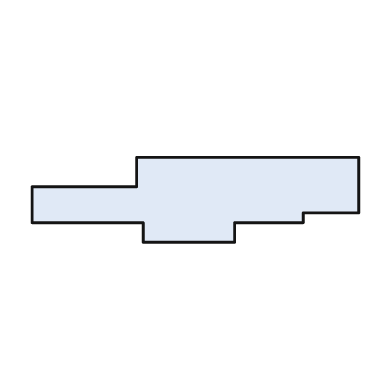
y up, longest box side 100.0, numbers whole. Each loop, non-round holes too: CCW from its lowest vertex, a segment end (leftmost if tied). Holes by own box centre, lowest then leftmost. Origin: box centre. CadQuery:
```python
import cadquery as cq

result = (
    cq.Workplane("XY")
    .moveTo(-16.0, -13.0)
    .lineTo(12.0, -13.0)
    .lineTo(12.0, -7.0)
    .lineTo(33.0, -7.0)
    .lineTo(33.0, -4.0)
    .lineTo(50.0, -4.0)
    .lineTo(50.0, 13.0)
    .lineTo(-18.0, 13.0)
    .lineTo(-18.0, 4.0)
    .lineTo(-50.0, 4.0)
    .lineTo(-50.0, -7.0)
    .lineTo(-16.0, -7.0)
    .close()
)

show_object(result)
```